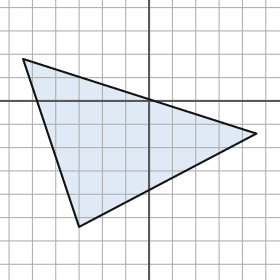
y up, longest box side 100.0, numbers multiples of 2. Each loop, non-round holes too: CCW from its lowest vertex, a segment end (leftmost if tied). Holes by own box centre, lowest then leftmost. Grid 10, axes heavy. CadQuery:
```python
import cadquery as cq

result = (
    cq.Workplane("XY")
    .moveTo(-30.0, -54.0)
    .lineTo(46.0, -14.0)
    .lineTo(-54.0, 18.0)
    .close()
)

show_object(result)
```